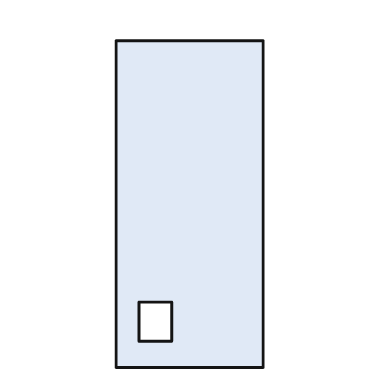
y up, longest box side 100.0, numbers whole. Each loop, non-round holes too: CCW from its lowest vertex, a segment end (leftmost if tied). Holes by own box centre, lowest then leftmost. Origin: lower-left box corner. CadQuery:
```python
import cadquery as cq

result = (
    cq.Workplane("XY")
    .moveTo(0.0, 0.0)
    .lineTo(45.0, 0.0)
    .lineTo(45.0, 100.0)
    .lineTo(0.0, 100.0)
    .close()
    .moveTo(7.0, 8.0)
    .lineTo(17.0, 8.0)
    .lineTo(17.0, 20.0)
    .lineTo(7.0, 20.0)
    .close()
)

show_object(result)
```